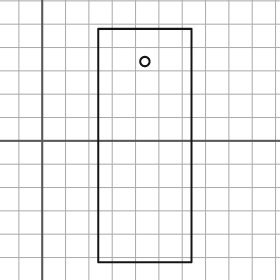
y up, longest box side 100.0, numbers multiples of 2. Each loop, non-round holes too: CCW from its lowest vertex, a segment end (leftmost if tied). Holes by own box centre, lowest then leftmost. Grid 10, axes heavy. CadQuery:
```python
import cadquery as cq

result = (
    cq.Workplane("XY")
    .moveTo(24.0, -52.0)
    .lineTo(64.0, -52.0)
    .lineTo(64.0, 48.0)
    .lineTo(24.0, 48.0)
    .close()
    .moveTo(44.0, 34.0)
    .circle(2.0)
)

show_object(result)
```